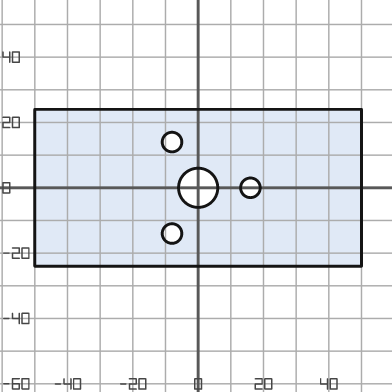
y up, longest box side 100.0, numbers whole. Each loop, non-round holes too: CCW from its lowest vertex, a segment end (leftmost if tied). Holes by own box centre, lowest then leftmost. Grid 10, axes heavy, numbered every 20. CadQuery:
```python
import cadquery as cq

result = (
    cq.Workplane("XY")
    .moveTo(-50.0, -24.0)
    .lineTo(50.0, -24.0)
    .lineTo(50.0, 24.0)
    .lineTo(-50.0, 24.0)
    .close()
    .moveTo(-8.0, -14.0)
    .circle(3.0)
    .moveTo(0.0, 0.0)
    .circle(6.0)
    .moveTo(16.0, 0.0)
    .circle(3.0)
    .moveTo(-8.0, 14.0)
    .circle(3.0)
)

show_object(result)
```